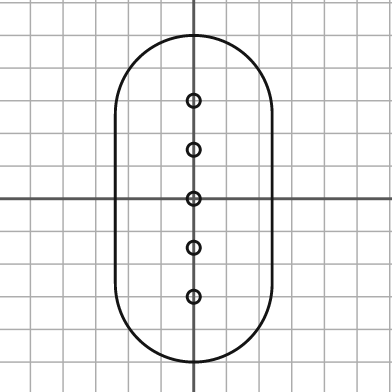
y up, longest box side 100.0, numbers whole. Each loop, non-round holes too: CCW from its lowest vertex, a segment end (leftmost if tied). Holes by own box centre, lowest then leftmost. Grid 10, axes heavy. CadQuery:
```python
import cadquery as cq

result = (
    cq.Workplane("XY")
    .moveTo(-24.0, -26.0)
    .threePointArc((0.0, -50.0), (24.0, -26.0))
    .lineTo(24.0, 26.0)
    .threePointArc((0.0, 50.0), (-24.0, 26.0))
    .close()
    .moveTo(0.0, -30.0)
    .circle(2.0)
    .moveTo(0.0, -15.0)
    .circle(2.0)
    .moveTo(0.0, 0.0)
    .circle(2.0)
    .moveTo(0.0, 15.0)
    .circle(2.0)
    .moveTo(0.0, 30.0)
    .circle(2.0)
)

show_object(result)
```